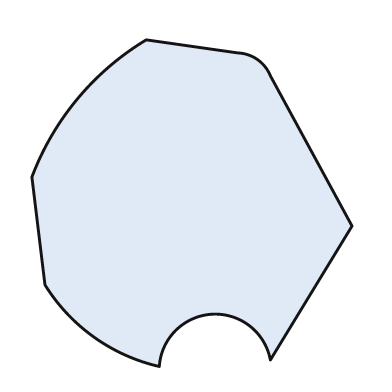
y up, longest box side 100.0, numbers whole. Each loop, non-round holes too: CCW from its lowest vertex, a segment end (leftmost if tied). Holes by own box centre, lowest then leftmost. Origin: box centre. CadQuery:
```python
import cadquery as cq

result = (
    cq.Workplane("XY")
    .moveTo(-10.0, -50.0)
    .threePointArc((6.0, -34.0), (24.0, -48.0))
    .lineTo(49.0, -7.0)
    .lineTo(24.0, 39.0)
    .threePointArc((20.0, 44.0), (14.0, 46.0))
    .lineTo(-14.0, 50.0)
    .threePointArc((-35.0, 32.0), (-49.0, 8.0))
    .lineTo(-45.0, -25.0)
    .threePointArc((-30.0, -41.0), (-10.0, -50.0))
    .close()
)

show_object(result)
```